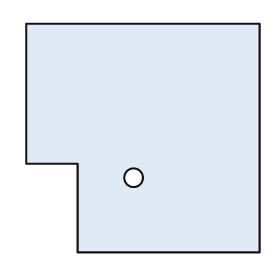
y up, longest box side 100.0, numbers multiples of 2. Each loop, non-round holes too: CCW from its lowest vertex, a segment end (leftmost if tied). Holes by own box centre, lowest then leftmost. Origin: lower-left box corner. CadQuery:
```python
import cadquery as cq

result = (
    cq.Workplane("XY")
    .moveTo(22.0, 0.0)
    .lineTo(100.0, 0.0)
    .lineTo(100.0, 98.0)
    .lineTo(0.0, 98.0)
    .lineTo(0.0, 38.0)
    .lineTo(22.0, 38.0)
    .close()
    .moveTo(46.0, 32.0)
    .circle(4.0)
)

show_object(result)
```